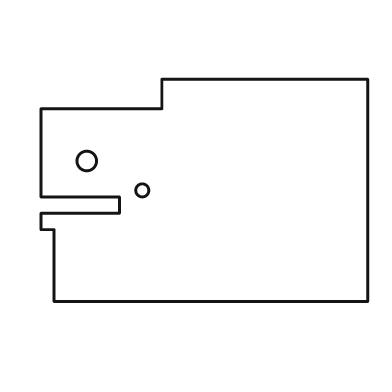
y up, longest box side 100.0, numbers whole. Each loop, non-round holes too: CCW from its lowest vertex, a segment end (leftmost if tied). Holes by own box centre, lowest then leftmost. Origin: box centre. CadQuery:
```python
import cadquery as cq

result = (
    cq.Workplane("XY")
    .moveTo(-46.0, -34.0)
    .lineTo(50.0, -34.0)
    .lineTo(50.0, 34.0)
    .lineTo(-13.0, 34.0)
    .lineTo(-13.0, 25.0)
    .lineTo(-50.0, 25.0)
    .lineTo(-50.0, -2.0)
    .lineTo(-26.0, -2.0)
    .lineTo(-26.0, -7.0)
    .lineTo(-50.0, -7.0)
    .lineTo(-50.0, -12.0)
    .lineTo(-46.0, -12.0)
    .close()
    .moveTo(-19.0, 0.0)
    .circle(2.0)
    .moveTo(-36.0, 9.0)
    .circle(3.0)
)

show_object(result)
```